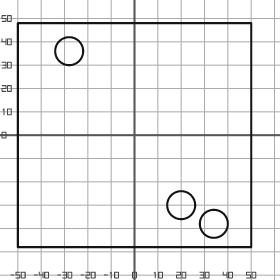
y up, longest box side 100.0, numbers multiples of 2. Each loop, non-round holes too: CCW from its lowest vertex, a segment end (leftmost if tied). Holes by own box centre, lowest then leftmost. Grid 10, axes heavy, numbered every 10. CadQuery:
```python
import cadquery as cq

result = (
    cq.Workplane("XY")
    .moveTo(-50.0, -48.0)
    .lineTo(50.0, -48.0)
    .lineTo(50.0, 48.0)
    .lineTo(-50.0, 48.0)
    .close()
    .moveTo(34.0, -38.0)
    .circle(6.0)
    .moveTo(20.0, -30.0)
    .circle(6.0)
    .moveTo(-28.0, 36.0)
    .circle(6.0)
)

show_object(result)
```